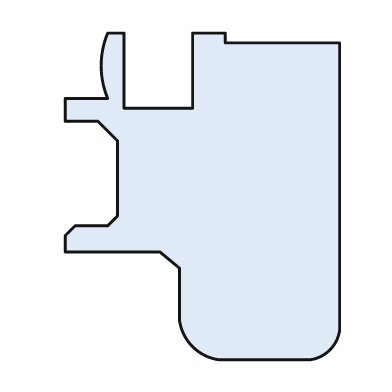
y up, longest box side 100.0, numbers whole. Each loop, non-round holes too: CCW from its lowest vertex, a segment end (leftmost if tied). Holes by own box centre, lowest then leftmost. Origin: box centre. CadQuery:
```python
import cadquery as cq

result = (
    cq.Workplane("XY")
    .moveTo(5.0, -50.0)
    .lineTo(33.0, -50.0)
    .threePointArc((39.0, -47.0), (42.0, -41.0))
    .lineTo(42.0, 47.0)
    .lineTo(7.0, 47.0)
    .lineTo(7.0, 50.0)
    .lineTo(-3.0, 50.0)
    .lineTo(-3.0, 27.0)
    .lineTo(-24.0, 27.0)
    .lineTo(-24.0, 50.0)
    .lineTo(-29.0, 50.0)
    .threePointArc((-31.0, 40.0), (-29.0, 30.0))
    .lineTo(-42.0, 30.0)
    .lineTo(-42.0, 23.0)
    .lineTo(-32.0, 23.0)
    .lineTo(-26.0, 17.0)
    .lineTo(-26.0, -6.0)
    .lineTo(-29.0, -9.0)
    .lineTo(-39.0, -9.0)
    .lineTo(-42.0, -12.0)
    .lineTo(-42.0, -17.0)
    .lineTo(-13.0, -17.0)
    .lineTo(-7.0, -22.0)
    .lineTo(-7.0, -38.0)
    .threePointArc((-3.0, -46.0), (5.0, -50.0))
    .close()
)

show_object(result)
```